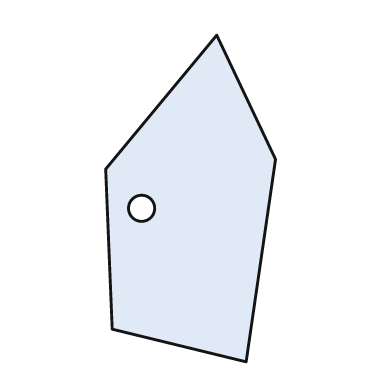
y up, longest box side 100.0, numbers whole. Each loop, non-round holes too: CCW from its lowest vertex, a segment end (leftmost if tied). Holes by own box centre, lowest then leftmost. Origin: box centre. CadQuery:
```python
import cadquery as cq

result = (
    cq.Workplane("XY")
    .moveTo(17.0, -50.0)
    .lineTo(26.0, 12.0)
    .lineTo(8.0, 50.0)
    .lineTo(-26.0, 9.0)
    .lineTo(-24.0, -40.0)
    .close()
    .moveTo(-15.0, -3.0)
    .circle(4.0)
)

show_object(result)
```